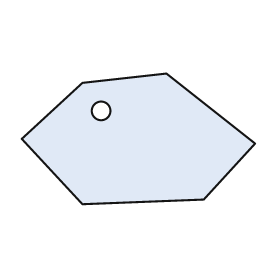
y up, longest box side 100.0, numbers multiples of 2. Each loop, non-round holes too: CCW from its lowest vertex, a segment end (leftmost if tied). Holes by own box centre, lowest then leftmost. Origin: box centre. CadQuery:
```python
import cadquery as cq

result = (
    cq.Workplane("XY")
    .moveTo(-24.0, -28.0)
    .lineTo(28.0, -26.0)
    .lineTo(50.0, -2.0)
    .lineTo(12.0, 28.0)
    .lineTo(-24.0, 24.0)
    .lineTo(-50.0, 0.0)
    .close()
    .moveTo(-16.0, 12.0)
    .circle(4.0)
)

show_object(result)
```